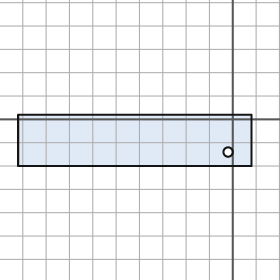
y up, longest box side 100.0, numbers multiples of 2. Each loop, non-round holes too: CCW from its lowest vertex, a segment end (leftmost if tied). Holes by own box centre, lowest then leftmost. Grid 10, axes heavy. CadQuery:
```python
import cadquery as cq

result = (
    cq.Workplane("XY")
    .moveTo(-92.0, -20.0)
    .lineTo(8.0, -20.0)
    .lineTo(8.0, 2.0)
    .lineTo(-92.0, 2.0)
    .close()
    .moveTo(-2.0, -14.0)
    .circle(2.0)
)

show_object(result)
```